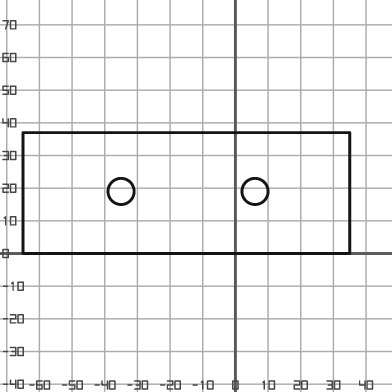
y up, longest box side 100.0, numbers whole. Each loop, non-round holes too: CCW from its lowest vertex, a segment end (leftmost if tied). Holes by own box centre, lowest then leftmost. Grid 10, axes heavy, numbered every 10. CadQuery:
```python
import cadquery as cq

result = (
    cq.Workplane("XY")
    .moveTo(-65.0, 0.0)
    .lineTo(35.0, 0.0)
    .lineTo(35.0, 37.0)
    .lineTo(-65.0, 37.0)
    .close()
    .moveTo(-35.0, 19.0)
    .circle(4.0)
    .moveTo(6.0, 19.0)
    .circle(4.0)
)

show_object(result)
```